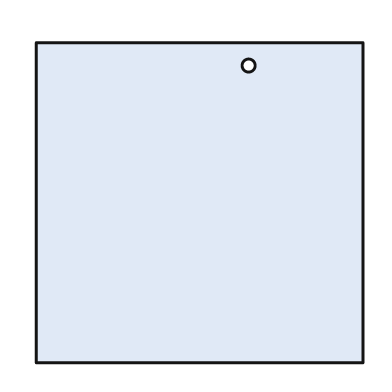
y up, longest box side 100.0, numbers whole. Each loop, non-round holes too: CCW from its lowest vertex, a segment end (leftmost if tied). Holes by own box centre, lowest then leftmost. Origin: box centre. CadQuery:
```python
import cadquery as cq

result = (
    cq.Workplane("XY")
    .moveTo(-50.0, -49.0)
    .lineTo(50.0, -49.0)
    .lineTo(50.0, 49.0)
    .lineTo(-50.0, 49.0)
    .close()
    .moveTo(15.0, 42.0)
    .circle(2.0)
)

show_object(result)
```